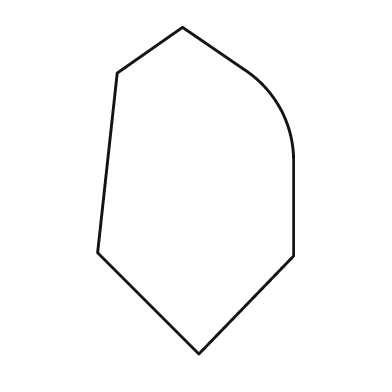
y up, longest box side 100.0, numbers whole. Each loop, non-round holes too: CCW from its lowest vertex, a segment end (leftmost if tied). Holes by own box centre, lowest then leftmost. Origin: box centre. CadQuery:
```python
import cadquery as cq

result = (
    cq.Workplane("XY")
    .moveTo(1.0, -50.0)
    .lineTo(30.0, -20.0)
    .lineTo(30.0, 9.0)
    .threePointArc((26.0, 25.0), (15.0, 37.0))
    .lineTo(-4.0, 50.0)
    .lineTo(-24.0, 36.0)
    .lineTo(-30.0, -19.0)
    .close()
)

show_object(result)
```